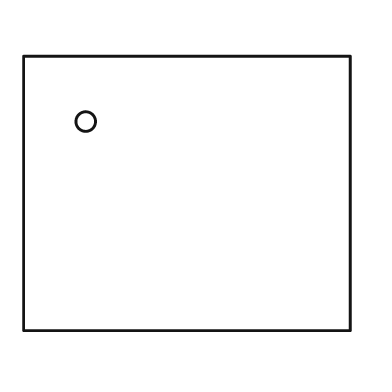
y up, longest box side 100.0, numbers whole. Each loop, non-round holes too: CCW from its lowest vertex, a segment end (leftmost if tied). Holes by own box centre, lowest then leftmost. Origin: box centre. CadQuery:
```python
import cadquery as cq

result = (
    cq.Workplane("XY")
    .moveTo(-50.0, -42.0)
    .lineTo(50.0, -42.0)
    .lineTo(50.0, 42.0)
    .lineTo(-50.0, 42.0)
    .close()
    .moveTo(-31.0, 22.0)
    .circle(3.0)
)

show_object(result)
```